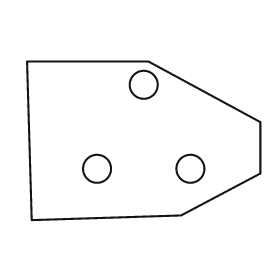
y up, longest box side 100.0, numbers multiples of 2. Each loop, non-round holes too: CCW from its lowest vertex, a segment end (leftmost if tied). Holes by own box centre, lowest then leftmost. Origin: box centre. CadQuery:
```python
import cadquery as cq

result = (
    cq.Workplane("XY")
    .moveTo(-48.0, -34.0)
    .lineTo(16.0, -32.0)
    .lineTo(50.0, -14.0)
    .lineTo(50.0, 8.0)
    .lineTo(2.0, 34.0)
    .lineTo(-50.0, 34.0)
    .close()
    .moveTo(-20.0, -12.0)
    .circle(6.0)
    .moveTo(20.0, -12.0)
    .circle(6.0)
    .moveTo(0.0, 24.0)
    .circle(6.0)
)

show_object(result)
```